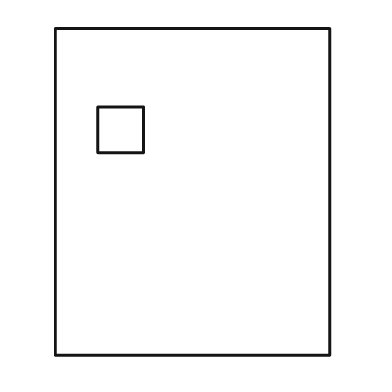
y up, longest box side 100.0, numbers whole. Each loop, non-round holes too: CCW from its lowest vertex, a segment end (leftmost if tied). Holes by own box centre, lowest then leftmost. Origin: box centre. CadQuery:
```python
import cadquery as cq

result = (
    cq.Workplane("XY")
    .moveTo(-42.0, -50.0)
    .lineTo(42.0, -50.0)
    .lineTo(42.0, 50.0)
    .lineTo(-42.0, 50.0)
    .close()
    .moveTo(-29.0, 12.0)
    .lineTo(-15.0, 12.0)
    .lineTo(-15.0, 26.0)
    .lineTo(-29.0, 26.0)
    .close()
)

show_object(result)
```